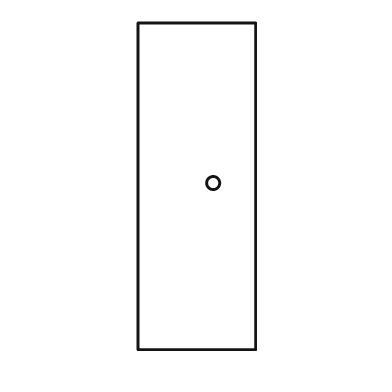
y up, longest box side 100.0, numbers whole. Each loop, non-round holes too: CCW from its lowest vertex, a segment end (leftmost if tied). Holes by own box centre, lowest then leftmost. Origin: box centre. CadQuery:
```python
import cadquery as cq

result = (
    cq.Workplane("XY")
    .moveTo(-18.0, -50.0)
    .lineTo(18.0, -50.0)
    .lineTo(18.0, 50.0)
    .lineTo(-18.0, 50.0)
    .close()
    .moveTo(5.0, 1.0)
    .circle(2.0)
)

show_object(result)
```